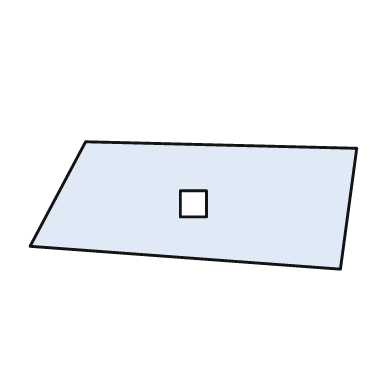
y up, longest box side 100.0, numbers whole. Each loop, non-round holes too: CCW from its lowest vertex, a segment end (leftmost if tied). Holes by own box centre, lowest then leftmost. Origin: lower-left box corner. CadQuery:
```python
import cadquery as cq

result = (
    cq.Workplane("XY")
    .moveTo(95.0, 0.0)
    .lineTo(100.0, 37.0)
    .lineTo(17.0, 39.0)
    .lineTo(0.0, 7.0)
    .close()
    .moveTo(46.0, 16.0)
    .lineTo(54.0, 16.0)
    .lineTo(54.0, 24.0)
    .lineTo(46.0, 24.0)
    .close()
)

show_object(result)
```